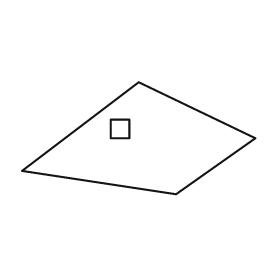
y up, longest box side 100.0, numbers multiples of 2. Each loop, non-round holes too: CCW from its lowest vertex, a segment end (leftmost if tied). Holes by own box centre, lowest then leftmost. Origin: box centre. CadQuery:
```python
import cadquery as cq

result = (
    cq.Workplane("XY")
    .moveTo(16.0, -24.0)
    .lineTo(50.0, 0.0)
    .lineTo(0.0, 24.0)
    .lineTo(-50.0, -14.0)
    .close()
    .moveTo(-12.0, 0.0)
    .lineTo(-4.0, 0.0)
    .lineTo(-4.0, 8.0)
    .lineTo(-12.0, 8.0)
    .close()
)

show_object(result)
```